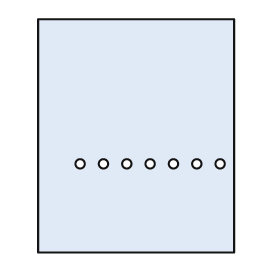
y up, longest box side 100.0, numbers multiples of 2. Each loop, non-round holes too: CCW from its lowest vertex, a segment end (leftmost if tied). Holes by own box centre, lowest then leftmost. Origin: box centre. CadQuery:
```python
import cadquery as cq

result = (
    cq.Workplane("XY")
    .moveTo(-42.0, -50.0)
    .lineTo(42.0, -50.0)
    .lineTo(42.0, 50.0)
    .lineTo(-42.0, 50.0)
    .close()
    .moveTo(-24.0, -12.0)
    .circle(2.0)
    .moveTo(-14.0, -12.0)
    .circle(2.0)
    .moveTo(-4.0, -12.0)
    .circle(2.0)
    .moveTo(6.0, -12.0)
    .circle(2.0)
    .moveTo(16.0, -12.0)
    .circle(2.0)
    .moveTo(26.0, -12.0)
    .circle(2.0)
    .moveTo(36.0, -12.0)
    .circle(2.0)
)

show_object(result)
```